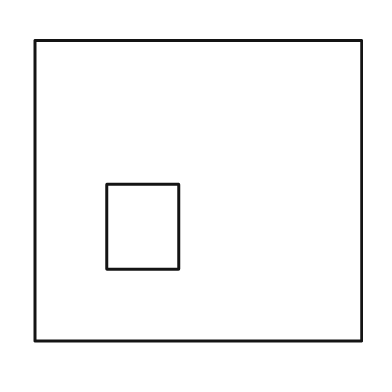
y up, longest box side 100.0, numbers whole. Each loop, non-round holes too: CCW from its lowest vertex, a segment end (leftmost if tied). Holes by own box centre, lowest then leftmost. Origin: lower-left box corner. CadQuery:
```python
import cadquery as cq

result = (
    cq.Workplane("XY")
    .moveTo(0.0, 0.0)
    .lineTo(100.0, 0.0)
    .lineTo(100.0, 92.0)
    .lineTo(0.0, 92.0)
    .close()
    .moveTo(22.0, 22.0)
    .lineTo(44.0, 22.0)
    .lineTo(44.0, 48.0)
    .lineTo(22.0, 48.0)
    .close()
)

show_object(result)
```